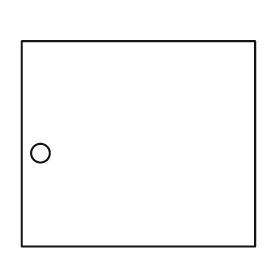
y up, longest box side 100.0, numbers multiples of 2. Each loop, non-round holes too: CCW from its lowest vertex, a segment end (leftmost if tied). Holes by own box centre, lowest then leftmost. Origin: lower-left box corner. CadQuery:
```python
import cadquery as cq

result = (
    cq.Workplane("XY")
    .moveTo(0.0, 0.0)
    .lineTo(100.0, 0.0)
    .lineTo(100.0, 88.0)
    .lineTo(0.0, 88.0)
    .close()
    .moveTo(8.0, 40.0)
    .circle(4.0)
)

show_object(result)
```